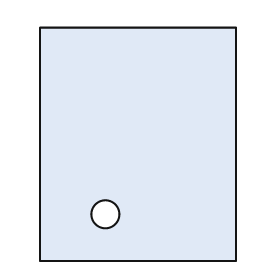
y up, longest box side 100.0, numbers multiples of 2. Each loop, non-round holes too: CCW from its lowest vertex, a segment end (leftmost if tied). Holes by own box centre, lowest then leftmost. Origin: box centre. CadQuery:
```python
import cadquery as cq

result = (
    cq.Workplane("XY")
    .moveTo(-42.0, -50.0)
    .lineTo(42.0, -50.0)
    .lineTo(42.0, 50.0)
    .lineTo(-42.0, 50.0)
    .close()
    .moveTo(-14.0, -30.0)
    .circle(6.0)
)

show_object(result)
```